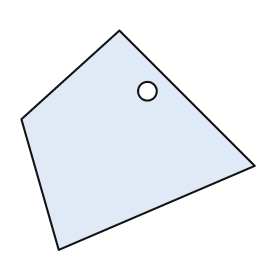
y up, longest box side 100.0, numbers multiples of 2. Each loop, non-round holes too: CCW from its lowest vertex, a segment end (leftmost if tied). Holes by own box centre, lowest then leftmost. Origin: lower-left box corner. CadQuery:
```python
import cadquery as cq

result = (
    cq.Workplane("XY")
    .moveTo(16.0, 0.0)
    .lineTo(100.0, 36.0)
    .lineTo(42.0, 94.0)
    .lineTo(0.0, 56.0)
    .close()
    .moveTo(54.0, 68.0)
    .circle(4.0)
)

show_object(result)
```